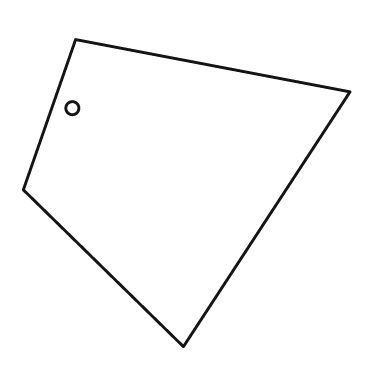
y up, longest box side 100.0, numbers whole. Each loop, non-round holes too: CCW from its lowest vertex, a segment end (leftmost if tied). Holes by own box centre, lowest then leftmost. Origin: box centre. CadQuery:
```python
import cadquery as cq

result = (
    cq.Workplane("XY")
    .moveTo(-1.0, -47.0)
    .lineTo(50.0, 31.0)
    .lineTo(-34.0, 47.0)
    .lineTo(-50.0, 1.0)
    .close()
    .moveTo(-35.0, 26.0)
    .circle(2.0)
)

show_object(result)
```